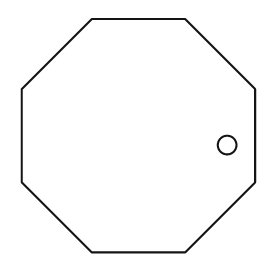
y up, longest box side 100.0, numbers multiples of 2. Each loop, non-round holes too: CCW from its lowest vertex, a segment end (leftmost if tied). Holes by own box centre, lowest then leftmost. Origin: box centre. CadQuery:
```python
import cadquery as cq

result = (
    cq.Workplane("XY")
    .moveTo(-20.0, -50.0)
    .lineTo(20.0, -50.0)
    .lineTo(50.0, -20.0)
    .lineTo(50.0, 20.0)
    .lineTo(20.0, 50.0)
    .lineTo(-20.0, 50.0)
    .lineTo(-50.0, 20.0)
    .lineTo(-50.0, -20.0)
    .close()
    .moveTo(38.0, -4.0)
    .circle(4.0)
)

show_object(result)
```